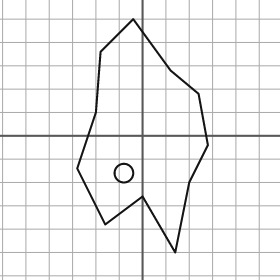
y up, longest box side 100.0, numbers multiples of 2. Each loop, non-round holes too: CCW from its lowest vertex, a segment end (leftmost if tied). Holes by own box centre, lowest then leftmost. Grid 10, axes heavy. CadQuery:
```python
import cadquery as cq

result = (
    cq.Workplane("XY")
    .moveTo(14.0, -50.0)
    .lineTo(20.0, -20.0)
    .lineTo(28.0, -4.0)
    .lineTo(24.0, 18.0)
    .lineTo(12.0, 28.0)
    .lineTo(-4.0, 50.0)
    .lineTo(-18.0, 36.0)
    .lineTo(-20.0, 10.0)
    .lineTo(-28.0, -14.0)
    .lineTo(-16.0, -38.0)
    .lineTo(0.0, -26.0)
    .close()
    .moveTo(-8.0, -16.0)
    .circle(4.0)
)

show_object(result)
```